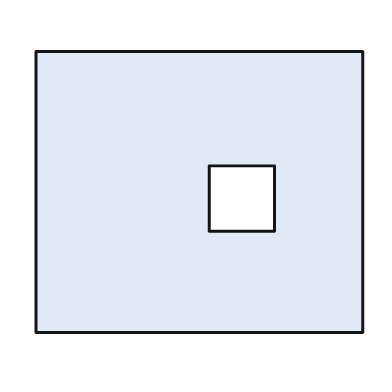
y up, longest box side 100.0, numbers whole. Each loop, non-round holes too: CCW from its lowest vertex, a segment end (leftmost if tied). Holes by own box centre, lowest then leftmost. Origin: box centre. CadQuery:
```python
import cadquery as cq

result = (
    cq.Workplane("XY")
    .moveTo(-50.0, -43.0)
    .lineTo(50.0, -43.0)
    .lineTo(50.0, 43.0)
    .lineTo(-50.0, 43.0)
    .close()
    .moveTo(3.0, -12.0)
    .lineTo(23.0, -12.0)
    .lineTo(23.0, 8.0)
    .lineTo(3.0, 8.0)
    .close()
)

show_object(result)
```